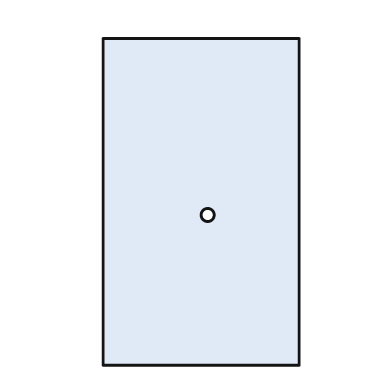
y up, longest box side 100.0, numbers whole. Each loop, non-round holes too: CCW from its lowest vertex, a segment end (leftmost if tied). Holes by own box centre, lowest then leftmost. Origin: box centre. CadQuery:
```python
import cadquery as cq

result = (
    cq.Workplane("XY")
    .moveTo(-30.0, -50.0)
    .lineTo(30.0, -50.0)
    .lineTo(30.0, 50.0)
    .lineTo(-30.0, 50.0)
    .close()
    .moveTo(2.0, -4.0)
    .circle(2.0)
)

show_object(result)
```